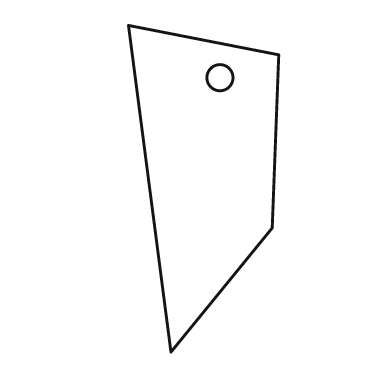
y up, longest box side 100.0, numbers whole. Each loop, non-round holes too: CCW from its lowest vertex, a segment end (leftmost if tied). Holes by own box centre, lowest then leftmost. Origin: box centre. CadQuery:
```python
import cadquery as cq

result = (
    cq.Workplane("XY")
    .moveTo(-10.0, -50.0)
    .lineTo(21.0, -12.0)
    .lineTo(23.0, 41.0)
    .lineTo(-23.0, 50.0)
    .close()
    .moveTo(5.0, 34.0)
    .circle(4.0)
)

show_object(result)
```